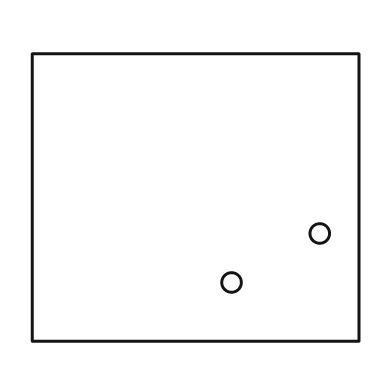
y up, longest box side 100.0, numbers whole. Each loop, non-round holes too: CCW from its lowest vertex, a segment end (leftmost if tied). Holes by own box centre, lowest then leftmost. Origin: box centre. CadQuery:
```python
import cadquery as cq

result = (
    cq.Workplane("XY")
    .moveTo(-50.0, -44.0)
    .lineTo(50.0, -44.0)
    .lineTo(50.0, 44.0)
    .lineTo(-50.0, 44.0)
    .close()
    .moveTo(11.0, -26.0)
    .circle(3.0)
    .moveTo(38.0, -11.0)
    .circle(3.0)
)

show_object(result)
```